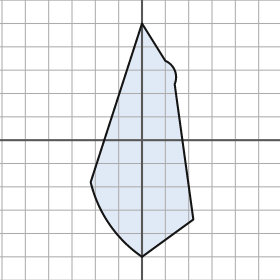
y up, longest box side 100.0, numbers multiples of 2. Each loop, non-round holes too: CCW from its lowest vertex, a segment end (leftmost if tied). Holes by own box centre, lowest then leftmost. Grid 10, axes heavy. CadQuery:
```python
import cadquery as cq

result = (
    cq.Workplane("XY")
    .moveTo(0.0, -50.0)
    .lineTo(22.0, -34.0)
    .lineTo(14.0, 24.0)
    .threePointArc((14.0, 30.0), (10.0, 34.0))
    .lineTo(0.0, 50.0)
    .lineTo(-22.0, -18.0)
    .threePointArc((-14.0, -36.0), (0.0, -50.0))
    .close()
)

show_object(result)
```